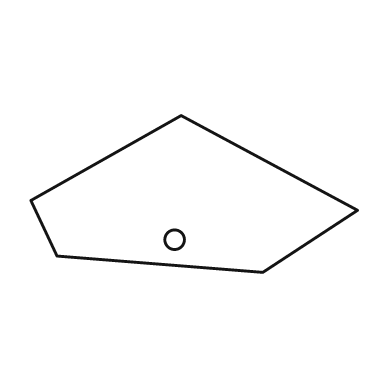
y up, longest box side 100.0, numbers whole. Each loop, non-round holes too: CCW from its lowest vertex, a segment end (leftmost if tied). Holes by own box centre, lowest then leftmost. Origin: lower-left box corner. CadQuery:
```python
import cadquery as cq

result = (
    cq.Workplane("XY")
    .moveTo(71.0, 0.0)
    .lineTo(100.0, 19.0)
    .lineTo(46.0, 48.0)
    .lineTo(0.0, 22.0)
    .lineTo(8.0, 5.0)
    .close()
    .moveTo(44.0, 10.0)
    .circle(3.0)
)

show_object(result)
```